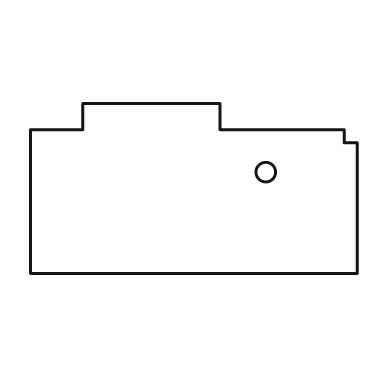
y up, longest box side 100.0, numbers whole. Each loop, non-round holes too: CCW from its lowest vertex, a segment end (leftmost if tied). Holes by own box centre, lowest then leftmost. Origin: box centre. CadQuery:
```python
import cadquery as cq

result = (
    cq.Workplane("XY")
    .moveTo(-50.0, -26.0)
    .lineTo(50.0, -26.0)
    .lineTo(50.0, 14.0)
    .lineTo(46.0, 14.0)
    .lineTo(46.0, 18.0)
    .lineTo(8.0, 18.0)
    .lineTo(8.0, 26.0)
    .lineTo(-34.0, 26.0)
    .lineTo(-34.0, 18.0)
    .lineTo(-50.0, 18.0)
    .close()
    .moveTo(22.0, 5.0)
    .circle(3.0)
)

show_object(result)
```